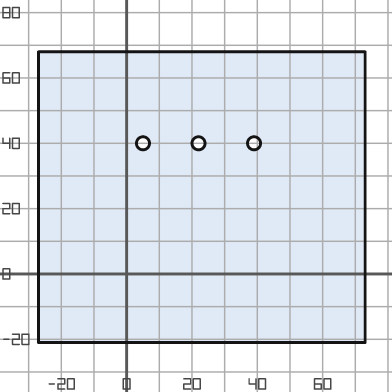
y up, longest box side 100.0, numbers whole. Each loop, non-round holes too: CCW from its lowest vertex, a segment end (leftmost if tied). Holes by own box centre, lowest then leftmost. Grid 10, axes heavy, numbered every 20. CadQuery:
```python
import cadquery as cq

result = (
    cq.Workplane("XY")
    .moveTo(-27.0, -21.0)
    .lineTo(73.0, -21.0)
    .lineTo(73.0, 68.0)
    .lineTo(-27.0, 68.0)
    .close()
    .moveTo(5.0, 40.0)
    .circle(2.0)
    .moveTo(22.0, 40.0)
    .circle(2.0)
    .moveTo(39.0, 40.0)
    .circle(2.0)
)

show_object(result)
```